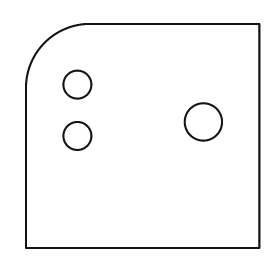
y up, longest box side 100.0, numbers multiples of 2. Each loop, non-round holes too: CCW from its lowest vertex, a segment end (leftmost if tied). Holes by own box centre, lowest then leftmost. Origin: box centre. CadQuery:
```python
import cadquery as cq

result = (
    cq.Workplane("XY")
    .moveTo(-50.0, -48.0)
    .lineTo(50.0, -48.0)
    .lineTo(50.0, 48.0)
    .lineTo(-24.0, 48.0)
    .threePointArc((-42.0, 40.0), (-50.0, 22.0))
    .close()
    .moveTo(-28.0, 0.0)
    .circle(6.0)
    .moveTo(26.0, 6.0)
    .circle(8.0)
    .moveTo(-28.0, 22.0)
    .circle(6.0)
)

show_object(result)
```